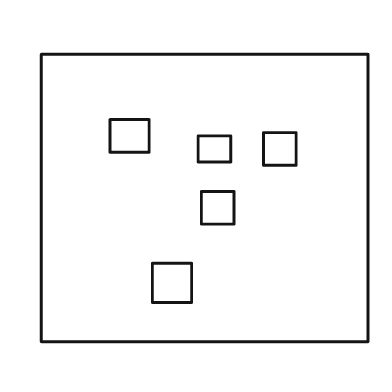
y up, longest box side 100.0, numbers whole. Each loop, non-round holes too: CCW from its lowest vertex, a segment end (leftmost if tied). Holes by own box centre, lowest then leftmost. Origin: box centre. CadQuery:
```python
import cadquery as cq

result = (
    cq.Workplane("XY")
    .moveTo(-50.0, -44.0)
    .lineTo(50.0, -44.0)
    .lineTo(50.0, 44.0)
    .lineTo(-50.0, 44.0)
    .close()
    .moveTo(-16.0, -32.0)
    .lineTo(-4.0, -32.0)
    .lineTo(-4.0, -20.0)
    .lineTo(-16.0, -20.0)
    .close()
    .moveTo(-1.0, -8.0)
    .lineTo(9.0, -8.0)
    .lineTo(9.0, 2.0)
    .lineTo(-1.0, 2.0)
    .close()
    .moveTo(-2.0, 11.0)
    .lineTo(8.0, 11.0)
    .lineTo(8.0, 19.0)
    .lineTo(-2.0, 19.0)
    .close()
    .moveTo(18.0, 10.0)
    .lineTo(28.0, 10.0)
    .lineTo(28.0, 20.0)
    .lineTo(18.0, 20.0)
    .close()
    .moveTo(-29.0, 14.0)
    .lineTo(-17.0, 14.0)
    .lineTo(-17.0, 24.0)
    .lineTo(-29.0, 24.0)
    .close()
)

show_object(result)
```